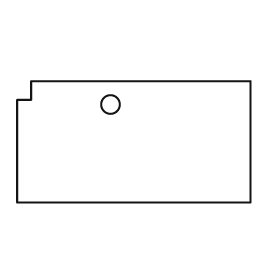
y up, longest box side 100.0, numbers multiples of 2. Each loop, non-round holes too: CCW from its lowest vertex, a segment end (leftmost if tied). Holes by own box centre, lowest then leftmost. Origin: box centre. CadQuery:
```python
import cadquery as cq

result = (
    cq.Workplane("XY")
    .moveTo(-50.0, -26.0)
    .lineTo(50.0, -26.0)
    .lineTo(50.0, 26.0)
    .lineTo(-44.0, 26.0)
    .lineTo(-44.0, 18.0)
    .lineTo(-50.0, 18.0)
    .close()
    .moveTo(-10.0, 16.0)
    .circle(4.0)
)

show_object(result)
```